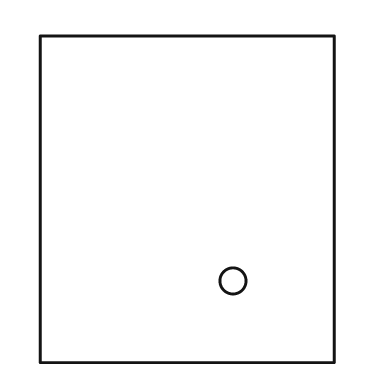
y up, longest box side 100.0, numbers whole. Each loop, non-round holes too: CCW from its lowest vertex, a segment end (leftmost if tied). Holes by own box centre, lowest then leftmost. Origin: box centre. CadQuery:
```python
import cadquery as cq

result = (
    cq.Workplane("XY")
    .moveTo(-45.0, -50.0)
    .lineTo(45.0, -50.0)
    .lineTo(45.0, 50.0)
    .lineTo(-45.0, 50.0)
    .close()
    .moveTo(14.0, -25.0)
    .circle(4.0)
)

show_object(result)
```